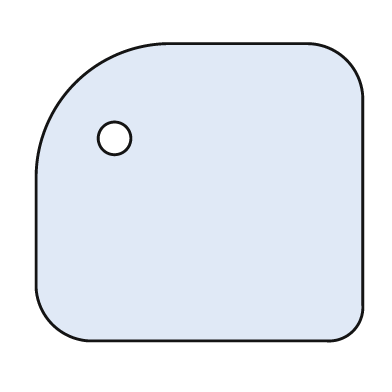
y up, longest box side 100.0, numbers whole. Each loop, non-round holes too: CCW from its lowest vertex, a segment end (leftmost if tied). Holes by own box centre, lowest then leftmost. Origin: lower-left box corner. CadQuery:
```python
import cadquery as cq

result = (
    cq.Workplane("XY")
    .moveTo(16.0, 0.0)
    .lineTo(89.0, 0.0)
    .threePointArc((97.0, 3.0), (100.0, 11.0))
    .lineTo(100.0, 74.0)
    .threePointArc((95.0, 86.0), (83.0, 91.0))
    .lineTo(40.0, 91.0)
    .threePointArc((12.0, 79.0), (0.0, 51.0))
    .lineTo(0.0, 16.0)
    .threePointArc((5.0, 5.0), (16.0, 0.0))
    .close()
    .moveTo(24.0, 62.0)
    .circle(5.0)
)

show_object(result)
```